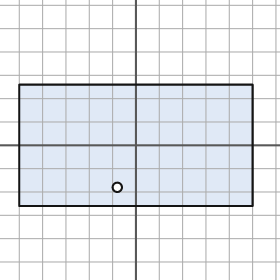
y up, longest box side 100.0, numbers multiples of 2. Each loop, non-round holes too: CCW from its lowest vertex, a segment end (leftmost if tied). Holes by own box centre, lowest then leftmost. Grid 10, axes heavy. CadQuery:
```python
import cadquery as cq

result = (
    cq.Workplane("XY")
    .moveTo(-50.0, -26.0)
    .lineTo(50.0, -26.0)
    .lineTo(50.0, 26.0)
    .lineTo(-50.0, 26.0)
    .close()
    .moveTo(-8.0, -18.0)
    .circle(2.0)
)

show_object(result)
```